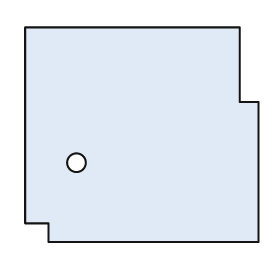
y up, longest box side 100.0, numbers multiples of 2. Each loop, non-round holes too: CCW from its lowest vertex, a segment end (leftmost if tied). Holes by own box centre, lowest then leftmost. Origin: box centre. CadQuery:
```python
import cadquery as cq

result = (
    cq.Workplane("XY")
    .moveTo(-40.0, -46.0)
    .lineTo(50.0, -46.0)
    .lineTo(50.0, 14.0)
    .lineTo(42.0, 14.0)
    .lineTo(42.0, 46.0)
    .lineTo(-50.0, 46.0)
    .lineTo(-50.0, -38.0)
    .lineTo(-40.0, -38.0)
    .close()
    .moveTo(-28.0, -12.0)
    .circle(4.0)
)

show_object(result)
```